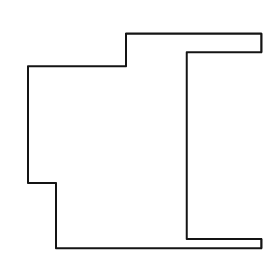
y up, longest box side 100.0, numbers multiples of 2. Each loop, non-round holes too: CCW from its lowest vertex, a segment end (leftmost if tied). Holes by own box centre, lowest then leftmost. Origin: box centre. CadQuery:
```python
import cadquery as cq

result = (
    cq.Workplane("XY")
    .moveTo(-38.0, -46.0)
    .lineTo(50.0, -46.0)
    .lineTo(50.0, -42.0)
    .lineTo(18.0, -42.0)
    .lineTo(18.0, 38.0)
    .lineTo(50.0, 38.0)
    .lineTo(50.0, 46.0)
    .lineTo(-8.0, 46.0)
    .lineTo(-8.0, 32.0)
    .lineTo(-50.0, 32.0)
    .lineTo(-50.0, -18.0)
    .lineTo(-38.0, -18.0)
    .close()
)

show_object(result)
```